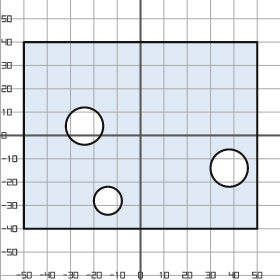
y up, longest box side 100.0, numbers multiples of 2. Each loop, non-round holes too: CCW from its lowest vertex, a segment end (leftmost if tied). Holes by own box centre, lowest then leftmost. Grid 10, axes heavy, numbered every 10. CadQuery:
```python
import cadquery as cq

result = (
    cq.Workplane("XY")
    .moveTo(-50.0, -40.0)
    .lineTo(50.0, -40.0)
    .lineTo(50.0, 40.0)
    .lineTo(-50.0, 40.0)
    .close()
    .moveTo(-14.0, -28.0)
    .circle(6.0)
    .moveTo(38.0, -14.0)
    .circle(8.0)
    .moveTo(-24.0, 4.0)
    .circle(8.0)
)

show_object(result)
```